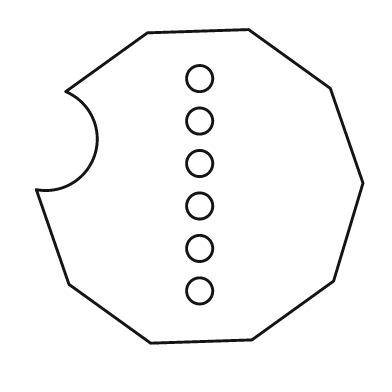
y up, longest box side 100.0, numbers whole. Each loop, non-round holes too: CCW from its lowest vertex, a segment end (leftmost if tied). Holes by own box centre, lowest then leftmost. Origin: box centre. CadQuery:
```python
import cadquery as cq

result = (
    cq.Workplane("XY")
    .moveTo(-15.0, -48.0)
    .lineTo(16.0, -47.0)
    .lineTo(41.0, -29.0)
    .lineTo(50.0, 1.0)
    .lineTo(40.0, 30.0)
    .lineTo(15.0, 48.0)
    .lineTo(-16.0, 47.0)
    .lineTo(-41.0, 29.0)
    .threePointArc((-32.0, 10.0), (-50.0, -1.0))
    .lineTo(-40.0, -30.0)
    .close()
    .moveTo(0.0, -32.0)
    .circle(4.0)
    .moveTo(0.0, -19.0)
    .circle(4.0)
    .moveTo(0.0, -6.0)
    .circle(4.0)
    .moveTo(0.0, 7.0)
    .circle(4.0)
    .moveTo(0.0, 20.0)
    .circle(4.0)
    .moveTo(0.0, 33.0)
    .circle(4.0)
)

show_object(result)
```